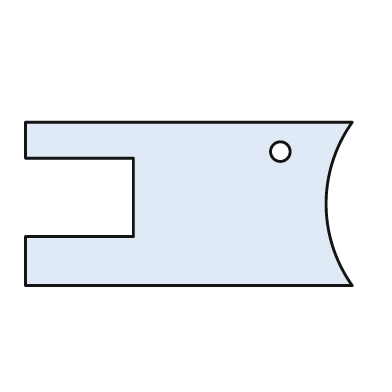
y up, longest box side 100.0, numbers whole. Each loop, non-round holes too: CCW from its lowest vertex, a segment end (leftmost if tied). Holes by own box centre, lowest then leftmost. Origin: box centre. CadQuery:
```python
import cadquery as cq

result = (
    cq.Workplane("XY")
    .moveTo(-50.0, -25.0)
    .lineTo(50.0, -25.0)
    .threePointArc((42.0, 0.0), (50.0, 25.0))
    .lineTo(-50.0, 25.0)
    .lineTo(-50.0, 14.0)
    .lineTo(-17.0, 14.0)
    .lineTo(-17.0, -10.0)
    .lineTo(-50.0, -10.0)
    .close()
    .moveTo(28.0, 16.0)
    .circle(3.0)
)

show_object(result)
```